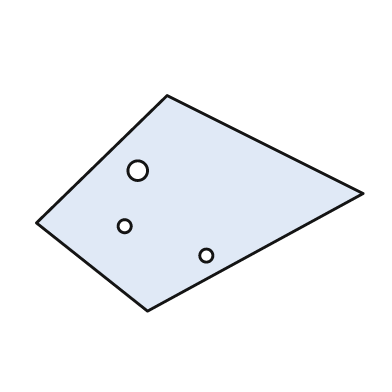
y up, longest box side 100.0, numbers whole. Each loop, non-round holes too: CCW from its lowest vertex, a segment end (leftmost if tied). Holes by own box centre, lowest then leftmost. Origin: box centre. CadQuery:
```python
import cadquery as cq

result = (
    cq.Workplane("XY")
    .moveTo(-16.0, -33.0)
    .lineTo(50.0, 3.0)
    .lineTo(-10.0, 33.0)
    .lineTo(-50.0, -6.0)
    .close()
    .moveTo(2.0, -16.0)
    .circle(2.0)
    .moveTo(-23.0, -7.0)
    .circle(2.0)
    .moveTo(-19.0, 10.0)
    .circle(3.0)
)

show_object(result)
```